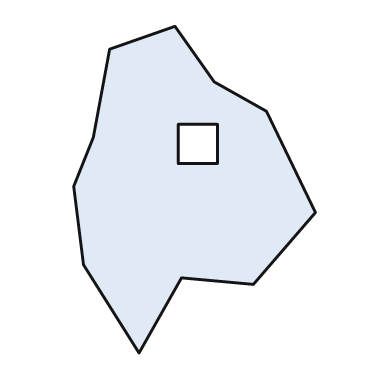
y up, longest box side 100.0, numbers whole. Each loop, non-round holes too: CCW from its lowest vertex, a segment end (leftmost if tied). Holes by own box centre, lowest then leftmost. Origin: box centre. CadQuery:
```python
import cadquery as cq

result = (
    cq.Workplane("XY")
    .moveTo(-17.0, -50.0)
    .lineTo(-4.0, -27.0)
    .lineTo(18.0, -29.0)
    .lineTo(37.0, -7.0)
    .lineTo(22.0, 24.0)
    .lineTo(6.0, 33.0)
    .lineTo(-6.0, 50.0)
    .lineTo(-26.0, 43.0)
    .lineTo(-31.0, 16.0)
    .lineTo(-37.0, 1.0)
    .lineTo(-34.0, -23.0)
    .close()
    .moveTo(-5.0, 8.0)
    .lineTo(7.0, 8.0)
    .lineTo(7.0, 20.0)
    .lineTo(-5.0, 20.0)
    .close()
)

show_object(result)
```